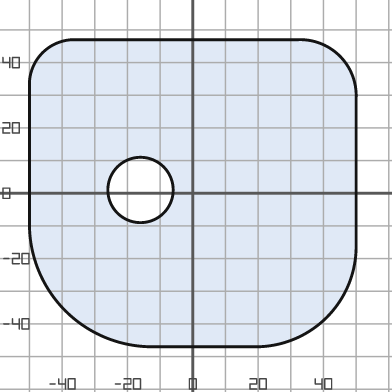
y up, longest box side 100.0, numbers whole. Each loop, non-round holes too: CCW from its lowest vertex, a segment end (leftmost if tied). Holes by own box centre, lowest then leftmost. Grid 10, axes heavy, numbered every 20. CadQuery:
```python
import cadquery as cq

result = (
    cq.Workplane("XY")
    .moveTo(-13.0, -47.0)
    .lineTo(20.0, -47.0)
    .threePointArc((41.0, -38.0), (50.0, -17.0))
    .lineTo(50.0, 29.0)
    .threePointArc((45.0, 42.0), (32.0, 47.0))
    .lineTo(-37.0, 47.0)
    .threePointArc((-46.0, 43.0), (-50.0, 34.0))
    .lineTo(-50.0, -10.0)
    .threePointArc((-39.0, -36.0), (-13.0, -47.0))
    .close()
    .moveTo(-16.0, 1.0)
    .circle(10.0)
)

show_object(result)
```